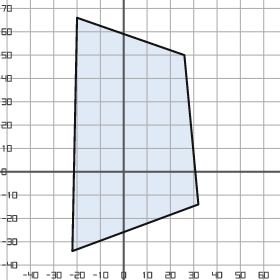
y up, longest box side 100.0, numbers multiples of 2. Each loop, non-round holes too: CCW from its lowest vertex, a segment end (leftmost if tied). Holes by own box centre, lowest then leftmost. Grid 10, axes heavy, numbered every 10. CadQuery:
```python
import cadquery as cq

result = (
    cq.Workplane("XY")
    .moveTo(-22.0, -34.0)
    .lineTo(32.0, -14.0)
    .lineTo(26.0, 50.0)
    .lineTo(-20.0, 66.0)
    .close()
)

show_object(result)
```